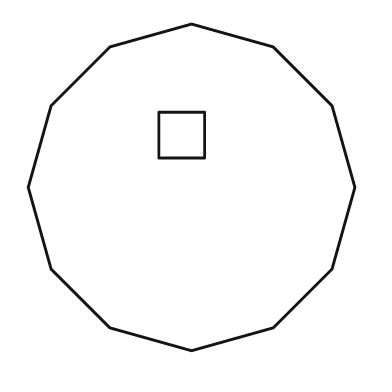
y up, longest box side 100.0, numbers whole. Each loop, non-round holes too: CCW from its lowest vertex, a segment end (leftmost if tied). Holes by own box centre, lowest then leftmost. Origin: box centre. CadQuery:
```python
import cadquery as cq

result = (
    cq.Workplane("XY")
    .moveTo(0.0, -50.0)
    .lineTo(25.0, -43.0)
    .lineTo(43.0, -25.0)
    .lineTo(50.0, 0.0)
    .lineTo(43.0, 25.0)
    .lineTo(25.0, 43.0)
    .lineTo(0.0, 50.0)
    .lineTo(-25.0, 43.0)
    .lineTo(-43.0, 25.0)
    .lineTo(-50.0, 0.0)
    .lineTo(-43.0, -25.0)
    .lineTo(-25.0, -43.0)
    .close()
    .moveTo(-10.0, 9.0)
    .lineTo(4.0, 9.0)
    .lineTo(4.0, 23.0)
    .lineTo(-10.0, 23.0)
    .close()
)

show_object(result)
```